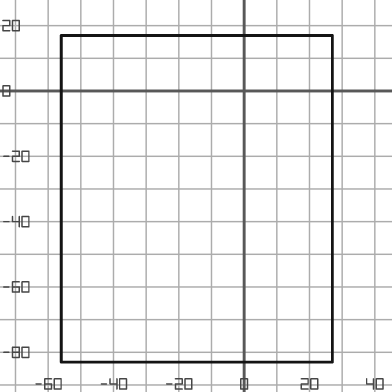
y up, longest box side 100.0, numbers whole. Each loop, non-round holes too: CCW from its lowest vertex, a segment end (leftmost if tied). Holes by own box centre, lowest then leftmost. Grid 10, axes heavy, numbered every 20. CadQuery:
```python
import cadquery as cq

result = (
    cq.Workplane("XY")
    .moveTo(-56.0, -83.0)
    .lineTo(27.0, -83.0)
    .lineTo(27.0, 17.0)
    .lineTo(-56.0, 17.0)
    .close()
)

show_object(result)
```